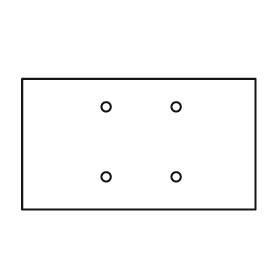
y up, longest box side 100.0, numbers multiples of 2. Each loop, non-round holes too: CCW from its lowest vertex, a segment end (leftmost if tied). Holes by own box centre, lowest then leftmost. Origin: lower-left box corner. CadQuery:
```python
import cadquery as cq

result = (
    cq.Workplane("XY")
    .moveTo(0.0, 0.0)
    .lineTo(100.0, 0.0)
    .lineTo(100.0, 56.0)
    .lineTo(0.0, 56.0)
    .close()
    .moveTo(36.0, 14.0)
    .circle(2.0)
    .moveTo(66.0, 14.0)
    .circle(2.0)
    .moveTo(36.0, 44.0)
    .circle(2.0)
    .moveTo(66.0, 44.0)
    .circle(2.0)
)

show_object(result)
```